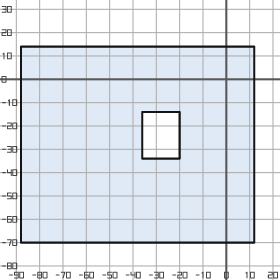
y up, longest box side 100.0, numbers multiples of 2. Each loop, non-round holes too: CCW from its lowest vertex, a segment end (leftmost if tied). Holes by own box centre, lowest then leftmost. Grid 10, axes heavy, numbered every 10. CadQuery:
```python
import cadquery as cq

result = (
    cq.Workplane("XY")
    .moveTo(-88.0, -70.0)
    .lineTo(12.0, -70.0)
    .lineTo(12.0, 14.0)
    .lineTo(-88.0, 14.0)
    .close()
    .moveTo(-36.0, -34.0)
    .lineTo(-20.0, -34.0)
    .lineTo(-20.0, -14.0)
    .lineTo(-36.0, -14.0)
    .close()
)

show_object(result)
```